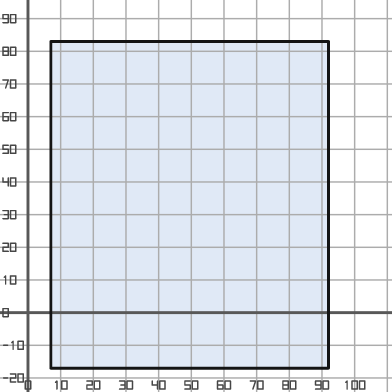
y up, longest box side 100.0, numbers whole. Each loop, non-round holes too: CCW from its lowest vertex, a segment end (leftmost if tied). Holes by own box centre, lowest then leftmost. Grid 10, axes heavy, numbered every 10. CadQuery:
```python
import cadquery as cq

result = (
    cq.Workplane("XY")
    .moveTo(7.0, -17.0)
    .lineTo(92.0, -17.0)
    .lineTo(92.0, 83.0)
    .lineTo(7.0, 83.0)
    .close()
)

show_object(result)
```